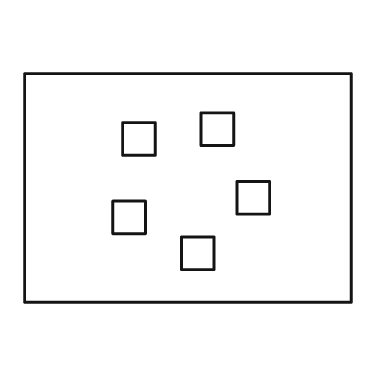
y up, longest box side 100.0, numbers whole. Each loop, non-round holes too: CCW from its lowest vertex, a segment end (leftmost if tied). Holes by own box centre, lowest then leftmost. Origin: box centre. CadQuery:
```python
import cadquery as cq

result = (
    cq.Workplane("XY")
    .moveTo(-50.0, -35.0)
    .lineTo(50.0, -35.0)
    .lineTo(50.0, 35.0)
    .lineTo(-50.0, 35.0)
    .close()
    .moveTo(-2.0, -25.0)
    .lineTo(8.0, -25.0)
    .lineTo(8.0, -15.0)
    .lineTo(-2.0, -15.0)
    .close()
    .moveTo(-23.0, -14.0)
    .lineTo(-13.0, -14.0)
    .lineTo(-13.0, -4.0)
    .lineTo(-23.0, -4.0)
    .close()
    .moveTo(15.0, -8.0)
    .lineTo(25.0, -8.0)
    .lineTo(25.0, 2.0)
    .lineTo(15.0, 2.0)
    .close()
    .moveTo(-20.0, 10.0)
    .lineTo(-10.0, 10.0)
    .lineTo(-10.0, 20.0)
    .lineTo(-20.0, 20.0)
    .close()
    .moveTo(4.0, 13.0)
    .lineTo(14.0, 13.0)
    .lineTo(14.0, 23.0)
    .lineTo(4.0, 23.0)
    .close()
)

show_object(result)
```